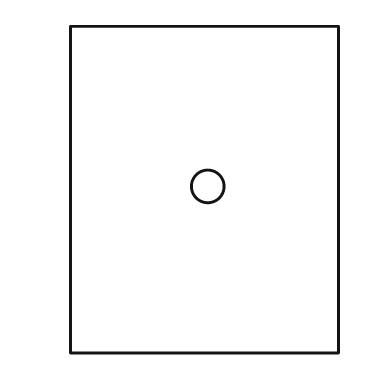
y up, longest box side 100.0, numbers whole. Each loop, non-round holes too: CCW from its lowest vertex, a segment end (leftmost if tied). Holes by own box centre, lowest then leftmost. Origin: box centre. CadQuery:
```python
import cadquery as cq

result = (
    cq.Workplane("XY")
    .moveTo(-41.0, -50.0)
    .lineTo(41.0, -50.0)
    .lineTo(41.0, 50.0)
    .lineTo(-41.0, 50.0)
    .close()
    .moveTo(1.0, 1.0)
    .circle(5.0)
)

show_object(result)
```